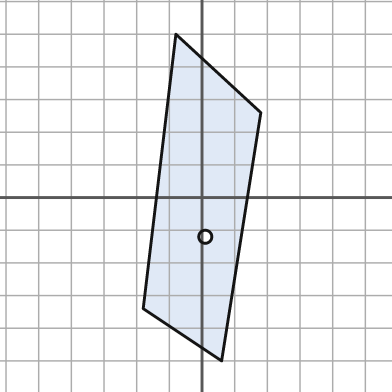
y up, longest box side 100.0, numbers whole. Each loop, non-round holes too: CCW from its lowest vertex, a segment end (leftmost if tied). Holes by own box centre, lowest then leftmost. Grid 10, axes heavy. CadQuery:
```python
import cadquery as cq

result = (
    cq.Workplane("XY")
    .moveTo(6.0, -50.0)
    .lineTo(18.0, 26.0)
    .lineTo(-8.0, 50.0)
    .lineTo(-18.0, -34.0)
    .close()
    .moveTo(1.0, -12.0)
    .circle(2.0)
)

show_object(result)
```